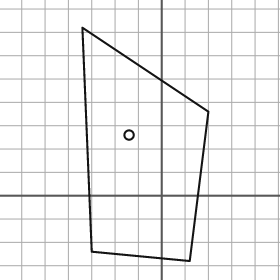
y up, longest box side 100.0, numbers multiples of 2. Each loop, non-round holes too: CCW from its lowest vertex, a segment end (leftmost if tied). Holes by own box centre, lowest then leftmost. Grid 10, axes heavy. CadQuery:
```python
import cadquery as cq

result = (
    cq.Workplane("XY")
    .moveTo(12.0, -28.0)
    .lineTo(20.0, 36.0)
    .lineTo(-34.0, 72.0)
    .lineTo(-30.0, -24.0)
    .close()
    .moveTo(-14.0, 26.0)
    .circle(2.0)
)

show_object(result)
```